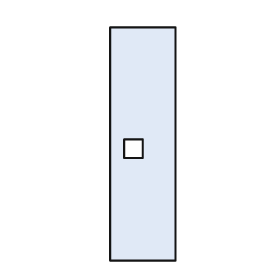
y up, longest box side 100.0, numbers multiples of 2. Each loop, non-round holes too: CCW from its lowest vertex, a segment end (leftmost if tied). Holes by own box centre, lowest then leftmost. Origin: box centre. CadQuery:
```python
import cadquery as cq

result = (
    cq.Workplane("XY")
    .moveTo(-14.0, -50.0)
    .lineTo(14.0, -50.0)
    .lineTo(14.0, 50.0)
    .lineTo(-14.0, 50.0)
    .close()
    .moveTo(-8.0, -6.0)
    .lineTo(0.0, -6.0)
    .lineTo(0.0, 2.0)
    .lineTo(-8.0, 2.0)
    .close()
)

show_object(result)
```